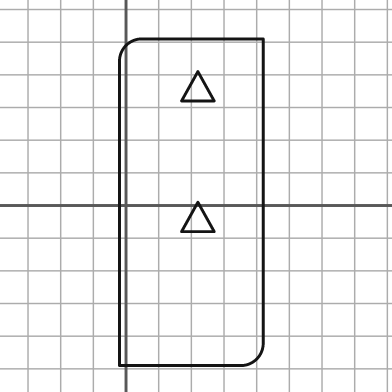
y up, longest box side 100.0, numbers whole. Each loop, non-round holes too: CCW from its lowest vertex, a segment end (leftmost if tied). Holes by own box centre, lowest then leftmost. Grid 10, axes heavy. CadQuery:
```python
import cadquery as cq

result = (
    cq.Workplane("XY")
    .moveTo(-2.0, -49.0)
    .lineTo(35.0, -49.0)
    .threePointArc((40.0, -47.0), (42.0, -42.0))
    .lineTo(42.0, 51.0)
    .lineTo(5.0, 51.0)
    .threePointArc((0.0, 49.0), (-2.0, 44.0))
    .close()
    .moveTo(17.0, -8.0)
    .lineTo(27.0, -8.0)
    .lineTo(22.0, 1.0)
    .close()
    .moveTo(17.0, 32.0)
    .lineTo(27.0, 32.0)
    .lineTo(22.0, 41.0)
    .close()
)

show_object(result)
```